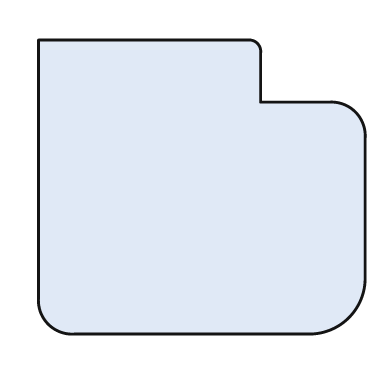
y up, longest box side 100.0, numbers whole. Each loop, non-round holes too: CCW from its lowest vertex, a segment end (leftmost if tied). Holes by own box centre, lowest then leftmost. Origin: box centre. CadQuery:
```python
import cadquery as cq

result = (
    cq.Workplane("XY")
    .moveTo(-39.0, -45.0)
    .lineTo(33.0, -45.0)
    .threePointArc((45.0, -40.0), (50.0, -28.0))
    .lineTo(50.0, 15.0)
    .threePointArc((47.0, 23.0), (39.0, 26.0))
    .lineTo(18.0, 26.0)
    .lineTo(18.0, 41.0)
    .threePointArc((17.0, 44.0), (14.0, 45.0))
    .lineTo(-50.0, 45.0)
    .lineTo(-50.0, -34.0)
    .threePointArc((-47.0, -42.0), (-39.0, -45.0))
    .close()
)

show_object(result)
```